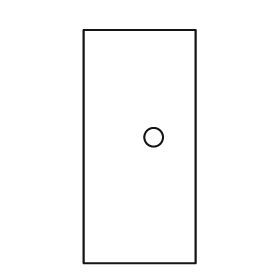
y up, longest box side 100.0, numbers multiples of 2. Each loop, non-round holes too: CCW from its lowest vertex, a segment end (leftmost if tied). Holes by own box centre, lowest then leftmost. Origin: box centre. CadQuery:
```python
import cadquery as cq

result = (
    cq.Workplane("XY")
    .moveTo(-24.0, -50.0)
    .lineTo(24.0, -50.0)
    .lineTo(24.0, 50.0)
    .lineTo(-24.0, 50.0)
    .close()
    .moveTo(6.0, 4.0)
    .circle(4.0)
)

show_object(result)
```